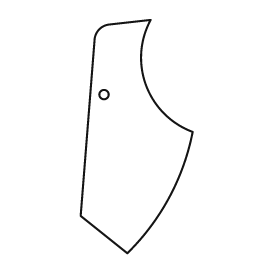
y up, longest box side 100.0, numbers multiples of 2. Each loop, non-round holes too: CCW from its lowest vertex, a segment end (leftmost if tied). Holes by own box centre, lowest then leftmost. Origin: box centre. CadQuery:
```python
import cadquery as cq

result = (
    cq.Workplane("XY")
    .moveTo(-4.0, -50.0)
    .threePointArc((14.0, -26.0), (24.0, 2.0))
    .threePointArc((4.0, 22.0), (6.0, 50.0))
    .lineTo(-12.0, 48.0)
    .threePointArc((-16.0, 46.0), (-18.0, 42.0))
    .lineTo(-24.0, -34.0)
    .close()
    .moveTo(-14.0, 18.0)
    .circle(2.0)
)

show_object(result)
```